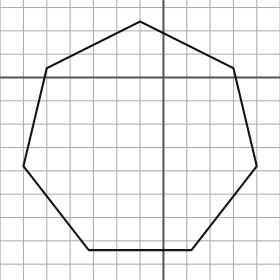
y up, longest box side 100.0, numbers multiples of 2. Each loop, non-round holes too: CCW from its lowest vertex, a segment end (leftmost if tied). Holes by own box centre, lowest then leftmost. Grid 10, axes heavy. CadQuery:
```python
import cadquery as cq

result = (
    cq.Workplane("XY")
    .moveTo(-32.0, -74.0)
    .lineTo(12.0, -74.0)
    .lineTo(40.0, -38.0)
    .lineTo(30.0, 4.0)
    .lineTo(-10.0, 24.0)
    .lineTo(-50.0, 4.0)
    .lineTo(-60.0, -38.0)
    .close()
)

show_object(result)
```